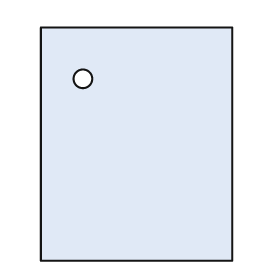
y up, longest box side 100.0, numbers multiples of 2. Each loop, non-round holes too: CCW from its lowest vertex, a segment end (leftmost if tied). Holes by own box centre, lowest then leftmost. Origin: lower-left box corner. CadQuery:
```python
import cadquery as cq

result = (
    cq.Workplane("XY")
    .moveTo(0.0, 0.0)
    .lineTo(82.0, 0.0)
    .lineTo(82.0, 100.0)
    .lineTo(0.0, 100.0)
    .close()
    .moveTo(18.0, 78.0)
    .circle(4.0)
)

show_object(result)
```